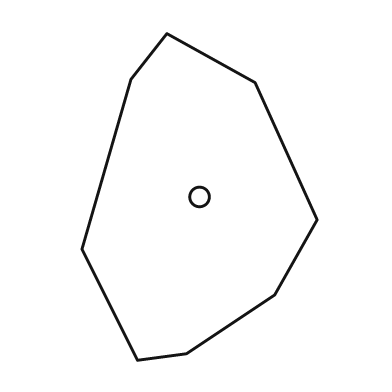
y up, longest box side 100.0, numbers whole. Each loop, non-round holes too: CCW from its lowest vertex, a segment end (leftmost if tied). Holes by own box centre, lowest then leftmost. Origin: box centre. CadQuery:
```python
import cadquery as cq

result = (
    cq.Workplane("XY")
    .moveTo(-19.0, -50.0)
    .lineTo(-4.0, -48.0)
    .lineTo(23.0, -30.0)
    .lineTo(36.0, -7.0)
    .lineTo(17.0, 35.0)
    .lineTo(-10.0, 50.0)
    .lineTo(-21.0, 36.0)
    .lineTo(-36.0, -16.0)
    .close()
    .moveTo(0.0, 0.0)
    .circle(3.0)
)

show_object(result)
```